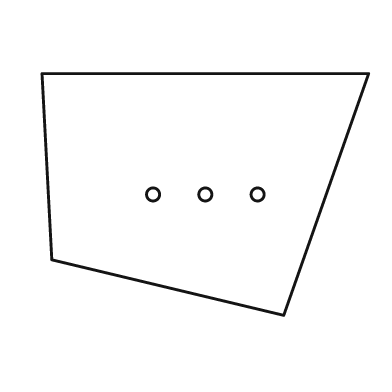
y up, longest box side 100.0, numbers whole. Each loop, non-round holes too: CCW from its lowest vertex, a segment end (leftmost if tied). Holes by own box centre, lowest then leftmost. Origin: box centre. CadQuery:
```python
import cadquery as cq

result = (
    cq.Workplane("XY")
    .moveTo(24.0, -37.0)
    .lineTo(50.0, 37.0)
    .lineTo(-50.0, 37.0)
    .lineTo(-47.0, -20.0)
    .close()
    .moveTo(-16.0, 0.0)
    .circle(2.0)
    .moveTo(0.0, 0.0)
    .circle(2.0)
    .moveTo(16.0, 0.0)
    .circle(2.0)
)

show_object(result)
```